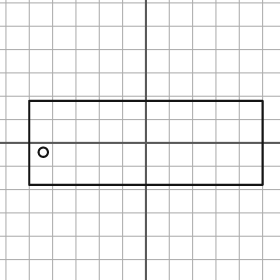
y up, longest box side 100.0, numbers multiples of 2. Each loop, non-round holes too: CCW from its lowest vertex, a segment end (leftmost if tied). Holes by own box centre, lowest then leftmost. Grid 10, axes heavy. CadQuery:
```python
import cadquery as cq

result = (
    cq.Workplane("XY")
    .moveTo(-50.0, -18.0)
    .lineTo(50.0, -18.0)
    .lineTo(50.0, 18.0)
    .lineTo(-50.0, 18.0)
    .close()
    .moveTo(-44.0, -4.0)
    .circle(2.0)
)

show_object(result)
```